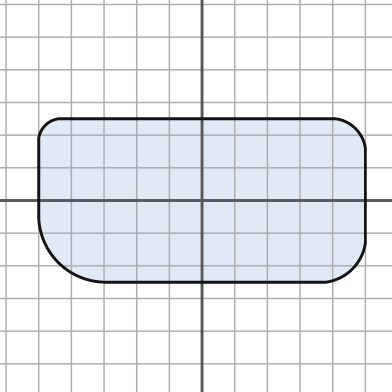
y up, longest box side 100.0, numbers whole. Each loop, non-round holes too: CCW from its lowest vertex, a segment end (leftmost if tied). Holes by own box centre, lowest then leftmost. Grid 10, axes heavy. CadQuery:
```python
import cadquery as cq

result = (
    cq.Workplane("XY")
    .moveTo(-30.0, -25.0)
    .lineTo(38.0, -25.0)
    .threePointArc((46.0, -21.0), (50.0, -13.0))
    .lineTo(50.0, 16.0)
    .threePointArc((47.0, 22.0), (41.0, 25.0))
    .lineTo(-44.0, 25.0)
    .threePointArc((-48.0, 23.0), (-50.0, 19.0))
    .lineTo(-50.0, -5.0)
    .threePointArc((-44.0, -19.0), (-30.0, -25.0))
    .close()
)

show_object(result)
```